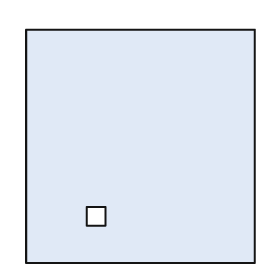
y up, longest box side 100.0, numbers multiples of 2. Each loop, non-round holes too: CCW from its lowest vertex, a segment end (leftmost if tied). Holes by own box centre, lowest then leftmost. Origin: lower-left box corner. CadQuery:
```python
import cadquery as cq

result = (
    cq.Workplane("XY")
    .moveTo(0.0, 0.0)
    .lineTo(98.0, 0.0)
    .lineTo(98.0, 100.0)
    .lineTo(0.0, 100.0)
    .close()
    .moveTo(26.0, 16.0)
    .lineTo(34.0, 16.0)
    .lineTo(34.0, 24.0)
    .lineTo(26.0, 24.0)
    .close()
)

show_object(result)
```